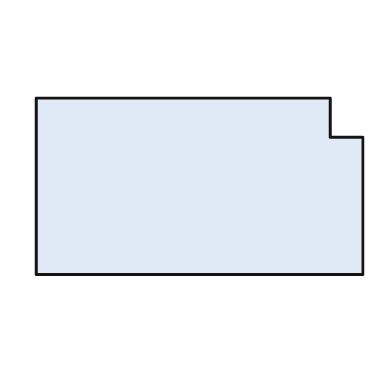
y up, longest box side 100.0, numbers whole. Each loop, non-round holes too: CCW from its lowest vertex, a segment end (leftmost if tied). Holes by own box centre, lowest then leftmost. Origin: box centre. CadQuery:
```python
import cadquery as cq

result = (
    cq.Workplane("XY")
    .moveTo(-50.0, -27.0)
    .lineTo(50.0, -27.0)
    .lineTo(50.0, 15.0)
    .lineTo(40.0, 15.0)
    .lineTo(40.0, 27.0)
    .lineTo(-50.0, 27.0)
    .close()
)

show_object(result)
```